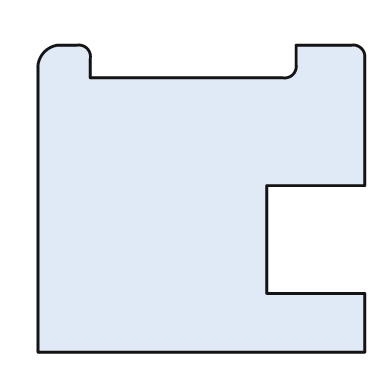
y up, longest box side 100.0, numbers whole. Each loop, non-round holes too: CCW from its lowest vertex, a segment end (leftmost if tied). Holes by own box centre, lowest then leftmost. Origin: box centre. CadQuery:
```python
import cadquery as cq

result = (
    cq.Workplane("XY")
    .moveTo(-50.0, -47.0)
    .lineTo(50.0, -47.0)
    .lineTo(50.0, -29.0)
    .lineTo(20.0, -29.0)
    .lineTo(20.0, 4.0)
    .lineTo(50.0, 4.0)
    .lineTo(50.0, 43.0)
    .threePointArc((49.0, 46.0), (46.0, 47.0))
    .lineTo(29.0, 47.0)
    .lineTo(29.0, 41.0)
    .threePointArc((28.0, 38.0), (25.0, 37.0))
    .lineTo(-34.0, 37.0)
    .lineTo(-34.0, 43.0)
    .threePointArc((-35.0, 46.0), (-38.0, 47.0))
    .lineTo(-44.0, 47.0)
    .threePointArc((-48.0, 45.0), (-50.0, 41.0))
    .close()
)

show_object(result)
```